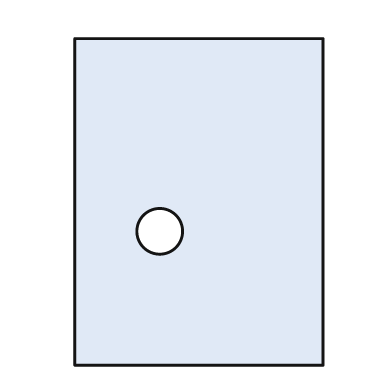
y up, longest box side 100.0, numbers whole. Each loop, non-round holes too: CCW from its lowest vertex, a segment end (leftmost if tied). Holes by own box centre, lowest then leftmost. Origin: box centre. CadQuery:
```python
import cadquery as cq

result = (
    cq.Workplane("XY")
    .moveTo(-38.0, -50.0)
    .lineTo(38.0, -50.0)
    .lineTo(38.0, 50.0)
    .lineTo(-38.0, 50.0)
    .close()
    .moveTo(-12.0, -9.0)
    .circle(7.0)
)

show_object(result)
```